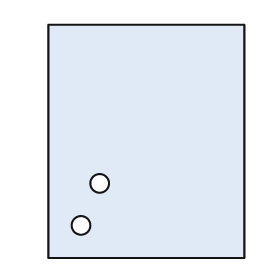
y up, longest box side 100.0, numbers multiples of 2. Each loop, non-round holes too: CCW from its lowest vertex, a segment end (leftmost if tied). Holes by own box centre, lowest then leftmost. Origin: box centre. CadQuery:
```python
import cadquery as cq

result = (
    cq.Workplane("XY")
    .moveTo(-42.0, -50.0)
    .lineTo(42.0, -50.0)
    .lineTo(42.0, 50.0)
    .lineTo(-42.0, 50.0)
    .close()
    .moveTo(-28.0, -36.0)
    .circle(4.0)
    .moveTo(-20.0, -18.0)
    .circle(4.0)
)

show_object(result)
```